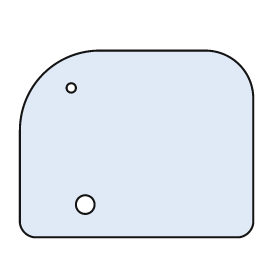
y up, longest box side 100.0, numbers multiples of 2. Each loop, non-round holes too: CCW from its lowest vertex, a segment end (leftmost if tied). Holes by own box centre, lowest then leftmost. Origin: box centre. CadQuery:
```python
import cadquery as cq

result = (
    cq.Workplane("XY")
    .moveTo(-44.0, -40.0)
    .lineTo(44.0, -40.0)
    .threePointArc((48.0, -38.0), (50.0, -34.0))
    .lineTo(50.0, 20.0)
    .threePointArc((44.0, 34.0), (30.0, 40.0))
    .lineTo(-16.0, 40.0)
    .threePointArc((-40.0, 30.0), (-50.0, 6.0))
    .lineTo(-50.0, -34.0)
    .threePointArc((-48.0, -38.0), (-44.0, -40.0))
    .close()
    .moveTo(-22.0, -26.0)
    .circle(4.0)
    .moveTo(-28.0, 24.0)
    .circle(2.0)
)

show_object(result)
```